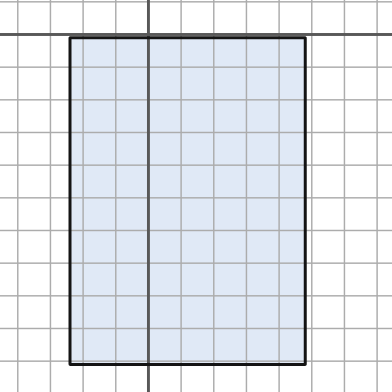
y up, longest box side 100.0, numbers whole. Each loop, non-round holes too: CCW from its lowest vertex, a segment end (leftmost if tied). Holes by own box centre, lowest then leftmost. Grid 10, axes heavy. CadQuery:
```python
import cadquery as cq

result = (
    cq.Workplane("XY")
    .moveTo(-24.0, -101.0)
    .lineTo(48.0, -101.0)
    .lineTo(48.0, -1.0)
    .lineTo(-24.0, -1.0)
    .close()
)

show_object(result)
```